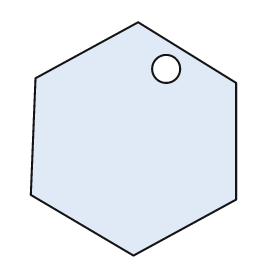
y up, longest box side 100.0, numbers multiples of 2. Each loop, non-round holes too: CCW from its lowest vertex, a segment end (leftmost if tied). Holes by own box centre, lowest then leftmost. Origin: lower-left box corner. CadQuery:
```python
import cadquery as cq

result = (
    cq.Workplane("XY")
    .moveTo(44.0, 0.0)
    .lineTo(88.0, 24.0)
    .lineTo(88.0, 74.0)
    .lineTo(46.0, 100.0)
    .lineTo(2.0, 76.0)
    .lineTo(0.0, 26.0)
    .close()
    .moveTo(58.0, 80.0)
    .circle(6.0)
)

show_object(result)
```